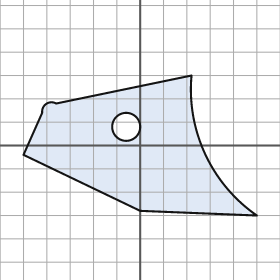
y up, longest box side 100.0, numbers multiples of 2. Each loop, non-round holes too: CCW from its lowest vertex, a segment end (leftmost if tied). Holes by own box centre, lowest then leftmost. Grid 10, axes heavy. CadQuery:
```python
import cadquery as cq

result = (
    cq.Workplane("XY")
    .moveTo(50.0, -30.0)
    .threePointArc((28.0, -4.0), (22.0, 30.0))
    .lineTo(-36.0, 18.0)
    .threePointArc((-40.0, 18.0), (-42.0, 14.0))
    .lineTo(-50.0, -4.0)
    .lineTo(0.0, -28.0)
    .close()
    .moveTo(-6.0, 8.0)
    .circle(6.0)
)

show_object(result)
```